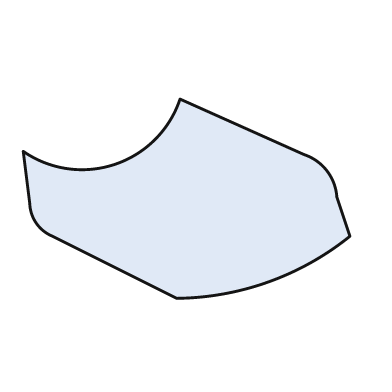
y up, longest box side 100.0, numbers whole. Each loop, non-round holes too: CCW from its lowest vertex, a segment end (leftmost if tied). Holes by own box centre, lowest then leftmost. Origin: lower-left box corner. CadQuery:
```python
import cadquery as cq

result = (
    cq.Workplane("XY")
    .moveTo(47.0, 0.0)
    .threePointArc((75.0, 5.0), (100.0, 19.0))
    .lineTo(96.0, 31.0)
    .threePointArc((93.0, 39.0), (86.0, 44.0))
    .lineTo(48.0, 61.0)
    .threePointArc((28.0, 41.0), (0.0, 45.0))
    .lineTo(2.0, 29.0)
    .threePointArc((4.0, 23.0), (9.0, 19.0))
    .close()
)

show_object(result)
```